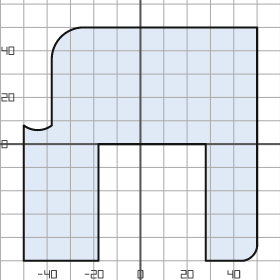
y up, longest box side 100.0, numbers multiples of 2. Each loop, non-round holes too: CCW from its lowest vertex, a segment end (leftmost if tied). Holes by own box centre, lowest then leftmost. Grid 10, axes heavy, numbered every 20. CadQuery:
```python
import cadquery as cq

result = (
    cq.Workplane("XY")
    .moveTo(-50.0, -50.0)
    .lineTo(-18.0, -50.0)
    .lineTo(-18.0, 0.0)
    .lineTo(28.0, 0.0)
    .lineTo(28.0, -50.0)
    .lineTo(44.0, -50.0)
    .threePointArc((48.0, -48.0), (50.0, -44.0))
    .lineTo(50.0, 50.0)
    .lineTo(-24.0, 50.0)
    .threePointArc((-34.0, 46.0), (-38.0, 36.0))
    .lineTo(-38.0, 8.0)
    .threePointArc((-44.0, 6.0), (-50.0, 8.0))
    .close()
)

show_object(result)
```